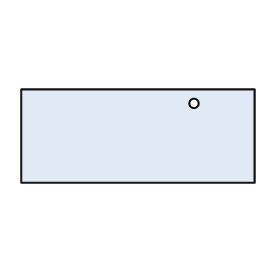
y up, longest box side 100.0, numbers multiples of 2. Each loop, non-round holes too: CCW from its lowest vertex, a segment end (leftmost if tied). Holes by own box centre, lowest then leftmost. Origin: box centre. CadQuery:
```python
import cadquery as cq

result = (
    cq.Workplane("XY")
    .moveTo(-50.0, -20.0)
    .lineTo(50.0, -20.0)
    .lineTo(50.0, 20.0)
    .lineTo(-50.0, 20.0)
    .close()
    .moveTo(24.0, 14.0)
    .circle(2.0)
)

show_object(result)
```